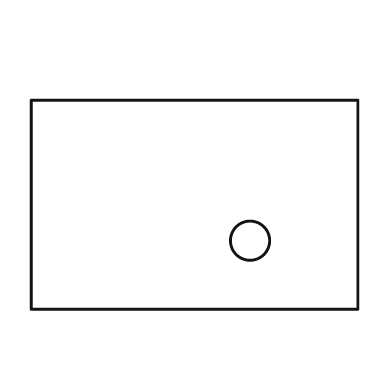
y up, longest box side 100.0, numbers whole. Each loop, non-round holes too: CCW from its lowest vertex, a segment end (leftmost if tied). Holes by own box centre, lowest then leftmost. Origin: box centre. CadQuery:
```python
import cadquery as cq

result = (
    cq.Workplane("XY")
    .moveTo(-50.0, -32.0)
    .lineTo(50.0, -32.0)
    .lineTo(50.0, 32.0)
    .lineTo(-50.0, 32.0)
    .close()
    .moveTo(17.0, -11.0)
    .circle(6.0)
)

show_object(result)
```